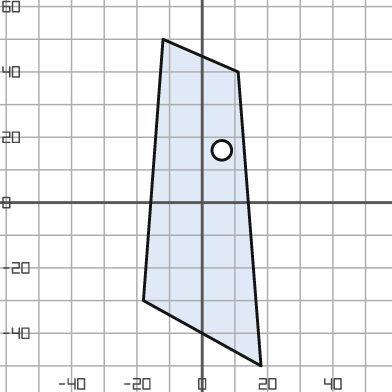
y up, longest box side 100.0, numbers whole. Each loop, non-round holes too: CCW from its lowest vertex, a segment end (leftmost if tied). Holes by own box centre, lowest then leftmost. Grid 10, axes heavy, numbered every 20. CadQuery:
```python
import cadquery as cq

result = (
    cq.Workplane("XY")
    .moveTo(18.0, -50.0)
    .lineTo(11.0, 40.0)
    .lineTo(-12.0, 50.0)
    .lineTo(-18.0, -30.0)
    .close()
    .moveTo(6.0, 16.0)
    .circle(3.0)
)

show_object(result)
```